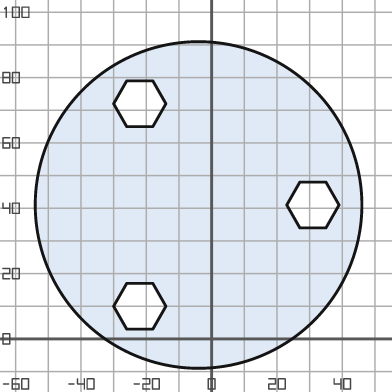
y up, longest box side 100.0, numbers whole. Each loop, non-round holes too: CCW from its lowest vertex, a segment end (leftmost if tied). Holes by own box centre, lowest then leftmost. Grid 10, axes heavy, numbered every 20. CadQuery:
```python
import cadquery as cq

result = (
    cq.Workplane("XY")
    .moveTo(-4.0, 41.0)
    .circle(50.0)
    .moveTo(-26.0, 3.0)
    .lineTo(-18.0, 3.0)
    .lineTo(-14.0, 10.0)
    .lineTo(-18.0, 17.0)
    .lineTo(-26.0, 17.0)
    .lineTo(-30.0, 10.0)
    .close()
    .moveTo(27.0, 34.0)
    .lineTo(35.0, 34.0)
    .lineTo(39.0, 41.0)
    .lineTo(35.0, 48.0)
    .lineTo(27.0, 48.0)
    .lineTo(23.0, 41.0)
    .close()
    .moveTo(-26.0, 65.0)
    .lineTo(-18.0, 65.0)
    .lineTo(-14.0, 72.0)
    .lineTo(-18.0, 79.0)
    .lineTo(-26.0, 79.0)
    .lineTo(-30.0, 72.0)
    .close()
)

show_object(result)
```